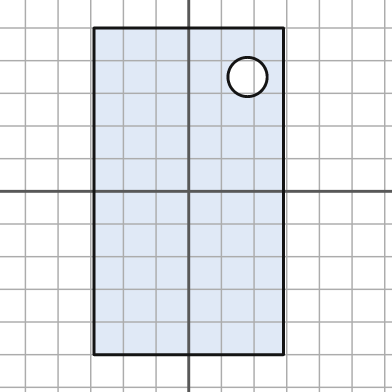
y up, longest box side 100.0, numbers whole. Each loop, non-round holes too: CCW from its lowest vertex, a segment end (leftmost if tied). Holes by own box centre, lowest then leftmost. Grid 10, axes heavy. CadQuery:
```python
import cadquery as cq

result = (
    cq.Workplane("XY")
    .moveTo(-29.0, -50.0)
    .lineTo(29.0, -50.0)
    .lineTo(29.0, 50.0)
    .lineTo(-29.0, 50.0)
    .close()
    .moveTo(18.0, 35.0)
    .circle(6.0)
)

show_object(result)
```